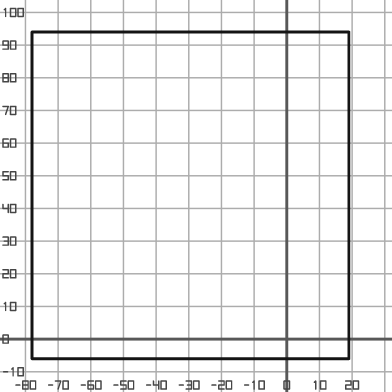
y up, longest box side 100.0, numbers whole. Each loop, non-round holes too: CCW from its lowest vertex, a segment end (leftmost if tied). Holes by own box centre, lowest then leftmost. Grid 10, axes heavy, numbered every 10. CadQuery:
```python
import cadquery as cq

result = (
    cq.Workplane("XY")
    .moveTo(-78.0, -6.0)
    .lineTo(19.0, -6.0)
    .lineTo(19.0, 94.0)
    .lineTo(-78.0, 94.0)
    .close()
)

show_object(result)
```